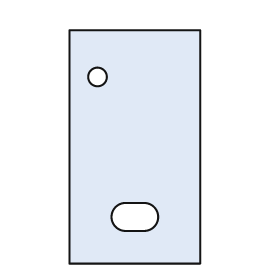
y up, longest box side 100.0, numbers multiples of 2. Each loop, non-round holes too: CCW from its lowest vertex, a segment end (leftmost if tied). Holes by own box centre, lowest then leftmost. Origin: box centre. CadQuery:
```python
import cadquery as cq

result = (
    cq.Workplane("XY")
    .moveTo(-28.0, -50.0)
    .lineTo(28.0, -50.0)
    .lineTo(28.0, 50.0)
    .lineTo(-28.0, 50.0)
    .close()
    .moveTo(-4.0, -36.0)
    .lineTo(4.0, -36.0)
    .threePointArc((10.0, -30.0), (4.0, -24.0))
    .lineTo(-4.0, -24.0)
    .threePointArc((-10.0, -30.0), (-4.0, -36.0))
    .close()
    .moveTo(-16.0, 30.0)
    .circle(4.0)
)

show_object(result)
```